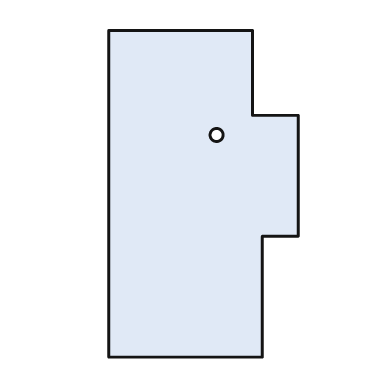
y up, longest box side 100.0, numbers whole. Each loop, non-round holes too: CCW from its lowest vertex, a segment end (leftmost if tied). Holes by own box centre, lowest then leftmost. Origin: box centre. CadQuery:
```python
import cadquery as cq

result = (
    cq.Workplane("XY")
    .moveTo(-29.0, -50.0)
    .lineTo(18.0, -50.0)
    .lineTo(18.0, -13.0)
    .lineTo(29.0, -13.0)
    .lineTo(29.0, 24.0)
    .lineTo(15.0, 24.0)
    .lineTo(15.0, 50.0)
    .lineTo(-29.0, 50.0)
    .close()
    .moveTo(4.0, 18.0)
    .circle(2.0)
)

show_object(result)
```